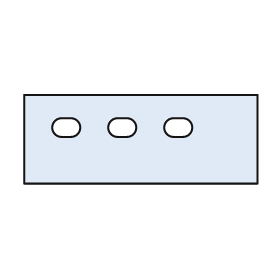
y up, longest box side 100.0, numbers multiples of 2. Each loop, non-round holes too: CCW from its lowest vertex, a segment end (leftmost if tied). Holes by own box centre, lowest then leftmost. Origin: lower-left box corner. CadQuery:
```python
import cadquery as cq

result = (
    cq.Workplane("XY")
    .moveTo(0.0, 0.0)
    .lineTo(100.0, 0.0)
    .lineTo(100.0, 38.0)
    .lineTo(0.0, 38.0)
    .close()
    .moveTo(16.0, 20.0)
    .lineTo(20.0, 20.0)
    .threePointArc((24.0, 24.0), (20.0, 28.0))
    .lineTo(16.0, 28.0)
    .threePointArc((12.0, 24.0), (16.0, 20.0))
    .close()
    .moveTo(40.0, 20.0)
    .lineTo(44.0, 20.0)
    .threePointArc((48.0, 24.0), (44.0, 28.0))
    .lineTo(40.0, 28.0)
    .threePointArc((36.0, 24.0), (40.0, 20.0))
    .close()
    .moveTo(64.0, 20.0)
    .lineTo(68.0, 20.0)
    .threePointArc((72.0, 24.0), (68.0, 28.0))
    .lineTo(64.0, 28.0)
    .threePointArc((60.0, 24.0), (64.0, 20.0))
    .close()
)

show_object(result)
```